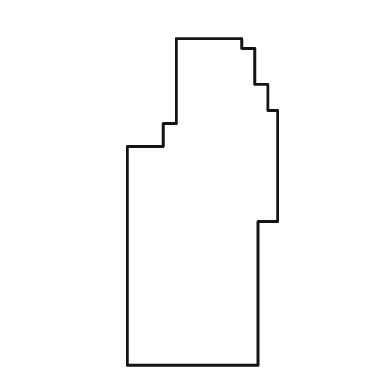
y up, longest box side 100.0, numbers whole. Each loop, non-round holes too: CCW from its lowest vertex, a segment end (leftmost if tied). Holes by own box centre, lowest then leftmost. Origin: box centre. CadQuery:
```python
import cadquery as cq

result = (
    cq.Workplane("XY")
    .moveTo(-23.0, -50.0)
    .lineTo(17.0, -50.0)
    .lineTo(17.0, -6.0)
    .lineTo(23.0, -6.0)
    .lineTo(23.0, 28.0)
    .lineTo(20.0, 28.0)
    .lineTo(20.0, 36.0)
    .lineTo(16.0, 36.0)
    .lineTo(16.0, 47.0)
    .lineTo(12.0, 47.0)
    .lineTo(12.0, 50.0)
    .lineTo(-8.0, 50.0)
    .lineTo(-8.0, 24.0)
    .lineTo(-12.0, 24.0)
    .lineTo(-12.0, 17.0)
    .lineTo(-23.0, 17.0)
    .close()
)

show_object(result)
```